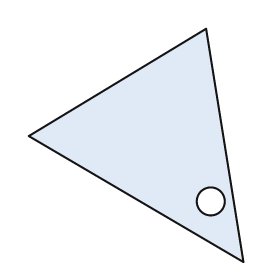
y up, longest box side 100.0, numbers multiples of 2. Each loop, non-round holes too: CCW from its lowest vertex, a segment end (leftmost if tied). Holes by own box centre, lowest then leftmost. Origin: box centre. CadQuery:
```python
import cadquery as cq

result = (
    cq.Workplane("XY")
    .moveTo(46.0, -50.0)
    .lineTo(30.0, 50.0)
    .lineTo(-46.0, 4.0)
    .close()
    .moveTo(32.0, -24.0)
    .circle(6.0)
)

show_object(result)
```